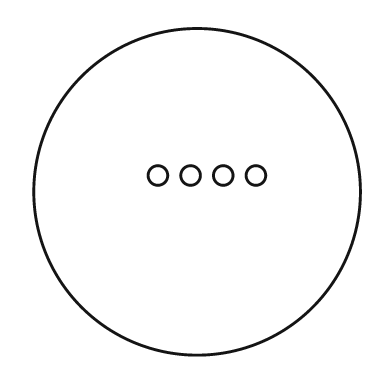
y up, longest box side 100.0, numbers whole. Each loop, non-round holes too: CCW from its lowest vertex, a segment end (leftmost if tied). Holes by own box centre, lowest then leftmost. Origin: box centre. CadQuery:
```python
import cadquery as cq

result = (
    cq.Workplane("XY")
    .moveTo(0.0, 0.0)
    .circle(50.0)
    .moveTo(-12.0, 5.0)
    .circle(3.0)
    .moveTo(-2.0, 5.0)
    .circle(3.0)
    .moveTo(8.0, 5.0)
    .circle(3.0)
    .moveTo(18.0, 5.0)
    .circle(3.0)
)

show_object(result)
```